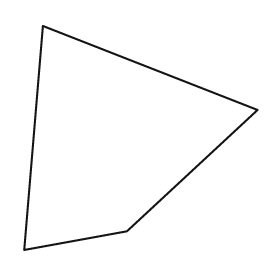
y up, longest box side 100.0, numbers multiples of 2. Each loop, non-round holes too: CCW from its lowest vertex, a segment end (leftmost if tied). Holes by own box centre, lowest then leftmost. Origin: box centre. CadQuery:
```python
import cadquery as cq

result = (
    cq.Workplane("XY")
    .moveTo(-50.0, -48.0)
    .lineTo(-6.0, -40.0)
    .lineTo(50.0, 12.0)
    .lineTo(-42.0, 48.0)
    .close()
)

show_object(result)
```